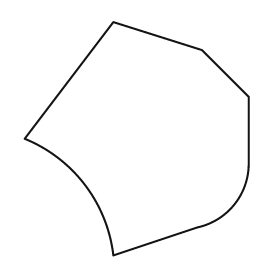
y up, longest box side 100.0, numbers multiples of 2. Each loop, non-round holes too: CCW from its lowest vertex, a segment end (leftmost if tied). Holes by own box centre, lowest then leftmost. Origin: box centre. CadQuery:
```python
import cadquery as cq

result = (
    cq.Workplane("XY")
    .moveTo(-10.0, -50.0)
    .lineTo(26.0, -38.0)
    .threePointArc((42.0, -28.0), (48.0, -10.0))
    .lineTo(48.0, 18.0)
    .lineTo(28.0, 38.0)
    .lineTo(-10.0, 50.0)
    .lineTo(-48.0, 0.0)
    .threePointArc((-22.0, -20.0), (-10.0, -50.0))
    .close()
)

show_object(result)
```